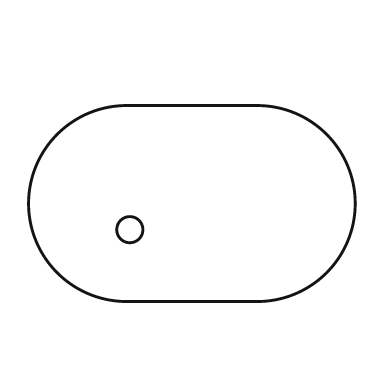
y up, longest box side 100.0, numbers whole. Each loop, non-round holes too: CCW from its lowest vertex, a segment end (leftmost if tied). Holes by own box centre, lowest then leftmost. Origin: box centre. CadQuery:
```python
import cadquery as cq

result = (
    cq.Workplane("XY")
    .moveTo(-20.0, -30.0)
    .lineTo(20.0, -30.0)
    .threePointArc((50.0, 0.0), (20.0, 30.0))
    .lineTo(-20.0, 30.0)
    .threePointArc((-50.0, 0.0), (-20.0, -30.0))
    .close()
    .moveTo(-19.0, -8.0)
    .circle(4.0)
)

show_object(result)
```